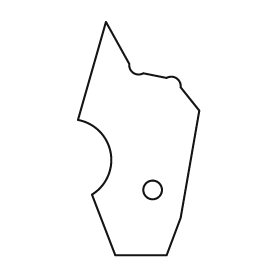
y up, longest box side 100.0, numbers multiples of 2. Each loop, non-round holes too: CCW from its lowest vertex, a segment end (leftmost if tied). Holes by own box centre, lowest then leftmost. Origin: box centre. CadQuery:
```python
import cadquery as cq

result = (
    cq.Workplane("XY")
    .moveTo(-10.0, -50.0)
    .lineTo(12.0, -50.0)
    .lineTo(18.0, -34.0)
    .lineTo(26.0, 12.0)
    .lineTo(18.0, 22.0)
    .threePointArc((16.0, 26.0), (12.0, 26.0))
    .lineTo(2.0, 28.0)
    .threePointArc((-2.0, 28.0), (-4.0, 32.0))
    .lineTo(-14.0, 50.0)
    .lineTo(-26.0, 8.0)
    .threePointArc((-12.0, -6.0), (-20.0, -24.0))
    .close()
    .moveTo(6.0, -22.0)
    .circle(4.0)
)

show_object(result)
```